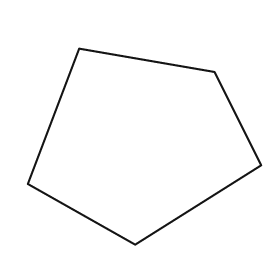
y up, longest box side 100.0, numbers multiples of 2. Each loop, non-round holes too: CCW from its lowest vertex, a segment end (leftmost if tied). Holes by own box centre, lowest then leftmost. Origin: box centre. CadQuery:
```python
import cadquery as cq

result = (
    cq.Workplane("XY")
    .moveTo(-4.0, -42.0)
    .lineTo(50.0, -8.0)
    .lineTo(30.0, 32.0)
    .lineTo(-28.0, 42.0)
    .lineTo(-50.0, -16.0)
    .close()
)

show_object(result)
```